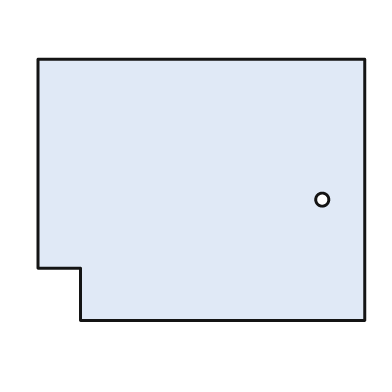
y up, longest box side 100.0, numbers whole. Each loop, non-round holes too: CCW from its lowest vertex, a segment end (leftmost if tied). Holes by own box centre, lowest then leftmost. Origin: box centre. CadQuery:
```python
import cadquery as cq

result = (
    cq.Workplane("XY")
    .moveTo(-37.0, -40.0)
    .lineTo(50.0, -40.0)
    .lineTo(50.0, 40.0)
    .lineTo(-50.0, 40.0)
    .lineTo(-50.0, -24.0)
    .lineTo(-37.0, -24.0)
    .close()
    .moveTo(37.0, -3.0)
    .circle(2.0)
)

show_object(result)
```